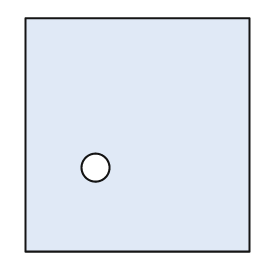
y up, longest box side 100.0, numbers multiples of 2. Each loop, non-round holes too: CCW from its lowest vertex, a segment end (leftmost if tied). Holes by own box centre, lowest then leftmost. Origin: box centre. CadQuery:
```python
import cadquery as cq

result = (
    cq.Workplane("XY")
    .moveTo(-48.0, -50.0)
    .lineTo(48.0, -50.0)
    .lineTo(48.0, 50.0)
    .lineTo(-48.0, 50.0)
    .close()
    .moveTo(-18.0, -14.0)
    .circle(6.0)
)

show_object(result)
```